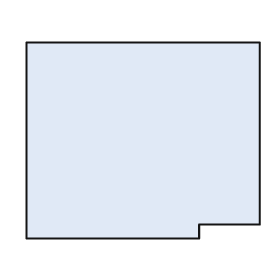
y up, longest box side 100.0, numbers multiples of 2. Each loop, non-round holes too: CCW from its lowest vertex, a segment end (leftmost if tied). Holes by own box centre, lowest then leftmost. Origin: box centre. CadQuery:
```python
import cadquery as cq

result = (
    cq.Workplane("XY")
    .moveTo(-50.0, -42.0)
    .lineTo(24.0, -42.0)
    .lineTo(24.0, -36.0)
    .lineTo(50.0, -36.0)
    .lineTo(50.0, 42.0)
    .lineTo(-50.0, 42.0)
    .close()
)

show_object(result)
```